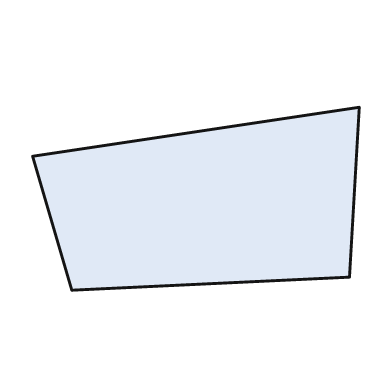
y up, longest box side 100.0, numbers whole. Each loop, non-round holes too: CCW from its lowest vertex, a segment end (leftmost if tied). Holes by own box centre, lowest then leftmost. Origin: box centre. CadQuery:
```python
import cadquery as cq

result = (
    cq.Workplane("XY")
    .moveTo(-38.0, -28.0)
    .lineTo(47.0, -24.0)
    .lineTo(50.0, 28.0)
    .lineTo(-50.0, 13.0)
    .close()
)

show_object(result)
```